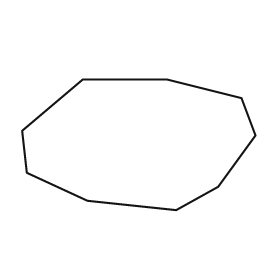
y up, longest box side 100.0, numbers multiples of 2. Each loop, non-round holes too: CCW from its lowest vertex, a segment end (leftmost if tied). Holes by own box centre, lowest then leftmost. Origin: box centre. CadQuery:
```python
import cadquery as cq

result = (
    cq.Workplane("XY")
    .moveTo(16.0, -28.0)
    .lineTo(34.0, -18.0)
    .lineTo(50.0, 4.0)
    .lineTo(44.0, 20.0)
    .lineTo(12.0, 28.0)
    .lineTo(-24.0, 28.0)
    .lineTo(-50.0, 6.0)
    .lineTo(-48.0, -12.0)
    .lineTo(-22.0, -24.0)
    .close()
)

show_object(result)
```